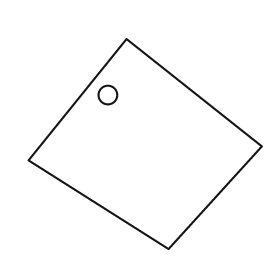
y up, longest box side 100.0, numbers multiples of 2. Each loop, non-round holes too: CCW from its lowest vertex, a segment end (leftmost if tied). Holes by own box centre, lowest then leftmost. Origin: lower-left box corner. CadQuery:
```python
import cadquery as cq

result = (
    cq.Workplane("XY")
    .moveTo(60.0, 0.0)
    .lineTo(100.0, 44.0)
    .lineTo(42.0, 90.0)
    .lineTo(0.0, 38.0)
    .close()
    .moveTo(34.0, 66.0)
    .circle(4.0)
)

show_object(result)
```